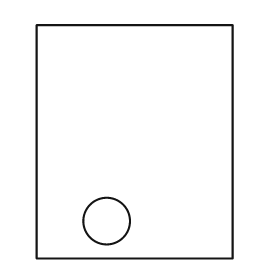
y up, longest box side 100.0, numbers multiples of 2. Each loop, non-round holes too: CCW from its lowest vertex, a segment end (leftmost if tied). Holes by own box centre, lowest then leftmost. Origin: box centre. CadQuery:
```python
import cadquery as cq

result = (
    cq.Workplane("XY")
    .moveTo(-42.0, -50.0)
    .lineTo(42.0, -50.0)
    .lineTo(42.0, 50.0)
    .lineTo(-42.0, 50.0)
    .close()
    .moveTo(-12.0, -34.0)
    .circle(10.0)
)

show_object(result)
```